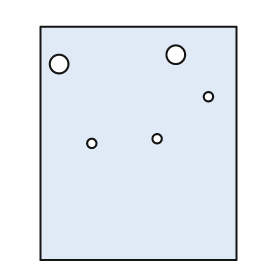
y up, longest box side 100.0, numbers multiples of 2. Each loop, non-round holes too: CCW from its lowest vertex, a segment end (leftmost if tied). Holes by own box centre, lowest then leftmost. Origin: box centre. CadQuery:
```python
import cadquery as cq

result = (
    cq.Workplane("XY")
    .moveTo(-42.0, -50.0)
    .lineTo(42.0, -50.0)
    .lineTo(42.0, 50.0)
    .lineTo(-42.0, 50.0)
    .close()
    .moveTo(-20.0, 0.0)
    .circle(2.0)
    .moveTo(8.0, 2.0)
    .circle(2.0)
    .moveTo(30.0, 20.0)
    .circle(2.0)
    .moveTo(-34.0, 34.0)
    .circle(4.0)
    .moveTo(16.0, 38.0)
    .circle(4.0)
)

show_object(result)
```